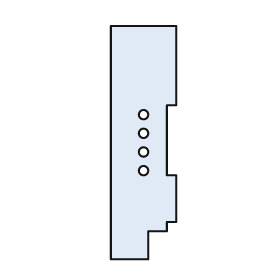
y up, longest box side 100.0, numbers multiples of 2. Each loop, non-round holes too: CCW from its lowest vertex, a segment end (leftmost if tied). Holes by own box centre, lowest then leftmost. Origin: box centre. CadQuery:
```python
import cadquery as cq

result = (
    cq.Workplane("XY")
    .moveTo(-14.0, -50.0)
    .lineTo(2.0, -50.0)
    .lineTo(2.0, -38.0)
    .lineTo(10.0, -38.0)
    .lineTo(10.0, -34.0)
    .lineTo(14.0, -34.0)
    .lineTo(14.0, -14.0)
    .lineTo(10.0, -14.0)
    .lineTo(10.0, 16.0)
    .lineTo(14.0, 16.0)
    .lineTo(14.0, 50.0)
    .lineTo(-14.0, 50.0)
    .close()
    .moveTo(0.0, -12.0)
    .circle(2.0)
    .moveTo(0.0, -4.0)
    .circle(2.0)
    .moveTo(0.0, 4.0)
    .circle(2.0)
    .moveTo(0.0, 12.0)
    .circle(2.0)
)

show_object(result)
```